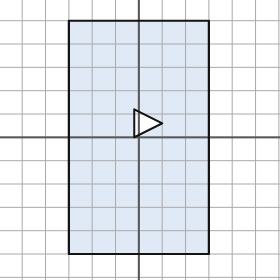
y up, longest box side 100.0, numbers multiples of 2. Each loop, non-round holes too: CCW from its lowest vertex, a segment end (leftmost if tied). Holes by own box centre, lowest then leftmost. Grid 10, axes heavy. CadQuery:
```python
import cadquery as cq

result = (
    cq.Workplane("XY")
    .moveTo(-30.0, -50.0)
    .lineTo(30.0, -50.0)
    .lineTo(30.0, 50.0)
    .lineTo(-30.0, 50.0)
    .close()
    .moveTo(-2.0, 0.0)
    .lineTo(10.0, 6.0)
    .lineTo(-2.0, 12.0)
    .close()
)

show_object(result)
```